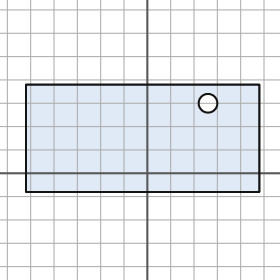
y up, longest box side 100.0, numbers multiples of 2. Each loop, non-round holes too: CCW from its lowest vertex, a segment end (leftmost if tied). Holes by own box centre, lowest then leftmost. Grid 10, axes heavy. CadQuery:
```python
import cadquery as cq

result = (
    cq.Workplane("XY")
    .moveTo(-52.0, -8.0)
    .lineTo(48.0, -8.0)
    .lineTo(48.0, 38.0)
    .lineTo(-52.0, 38.0)
    .close()
    .moveTo(26.0, 30.0)
    .circle(4.0)
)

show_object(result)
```